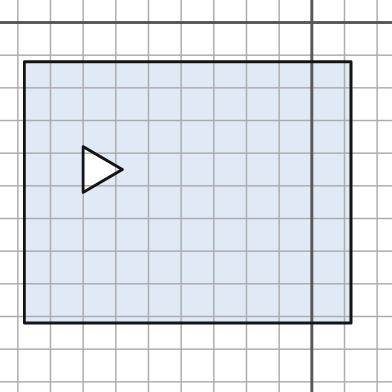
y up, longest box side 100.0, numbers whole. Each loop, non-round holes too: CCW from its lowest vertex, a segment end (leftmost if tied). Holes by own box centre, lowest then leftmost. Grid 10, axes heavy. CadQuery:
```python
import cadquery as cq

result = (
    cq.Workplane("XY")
    .moveTo(-88.0, -92.0)
    .lineTo(12.0, -92.0)
    .lineTo(12.0, -12.0)
    .lineTo(-88.0, -12.0)
    .close()
    .moveTo(-70.0, -52.0)
    .lineTo(-58.0, -45.0)
    .lineTo(-70.0, -38.0)
    .close()
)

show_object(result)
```